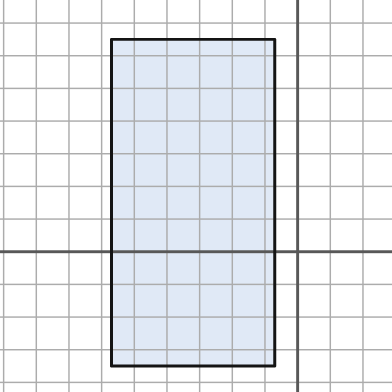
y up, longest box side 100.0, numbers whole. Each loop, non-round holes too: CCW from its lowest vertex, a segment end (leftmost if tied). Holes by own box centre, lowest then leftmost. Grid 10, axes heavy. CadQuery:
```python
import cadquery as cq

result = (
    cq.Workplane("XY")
    .moveTo(-57.0, -35.0)
    .lineTo(-7.0, -35.0)
    .lineTo(-7.0, 65.0)
    .lineTo(-57.0, 65.0)
    .close()
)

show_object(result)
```